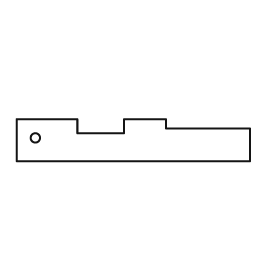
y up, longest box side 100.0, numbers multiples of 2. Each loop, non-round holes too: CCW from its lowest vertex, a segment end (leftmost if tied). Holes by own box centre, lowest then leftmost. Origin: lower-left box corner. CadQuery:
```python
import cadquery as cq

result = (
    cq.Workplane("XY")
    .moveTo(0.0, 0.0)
    .lineTo(100.0, 0.0)
    .lineTo(100.0, 14.0)
    .lineTo(64.0, 14.0)
    .lineTo(64.0, 18.0)
    .lineTo(46.0, 18.0)
    .lineTo(46.0, 12.0)
    .lineTo(26.0, 12.0)
    .lineTo(26.0, 18.0)
    .lineTo(0.0, 18.0)
    .close()
    .moveTo(8.0, 10.0)
    .circle(2.0)
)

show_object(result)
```